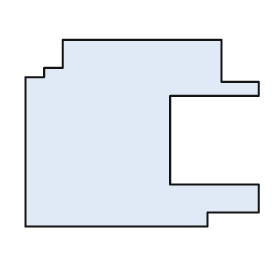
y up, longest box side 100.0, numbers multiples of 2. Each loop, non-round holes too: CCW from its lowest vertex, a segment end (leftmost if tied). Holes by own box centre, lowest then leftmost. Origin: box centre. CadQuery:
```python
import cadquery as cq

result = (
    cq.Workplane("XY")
    .moveTo(-50.0, -40.0)
    .lineTo(28.0, -40.0)
    .lineTo(28.0, -34.0)
    .lineTo(50.0, -34.0)
    .lineTo(50.0, -22.0)
    .lineTo(12.0, -22.0)
    .lineTo(12.0, 16.0)
    .lineTo(50.0, 16.0)
    .lineTo(50.0, 22.0)
    .lineTo(34.0, 22.0)
    .lineTo(34.0, 40.0)
    .lineTo(-34.0, 40.0)
    .lineTo(-34.0, 28.0)
    .lineTo(-42.0, 28.0)
    .lineTo(-42.0, 24.0)
    .lineTo(-50.0, 24.0)
    .close()
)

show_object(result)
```